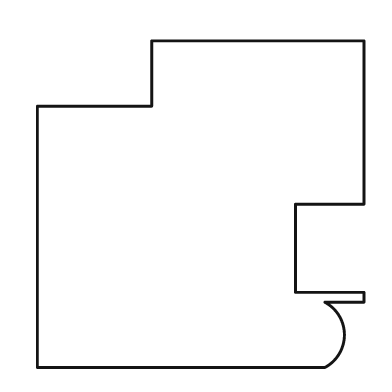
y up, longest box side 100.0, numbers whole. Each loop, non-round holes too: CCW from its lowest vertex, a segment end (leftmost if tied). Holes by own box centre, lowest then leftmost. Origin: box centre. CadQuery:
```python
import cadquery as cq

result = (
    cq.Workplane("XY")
    .moveTo(-50.0, -50.0)
    .lineTo(38.0, -50.0)
    .threePointArc((44.0, -40.0), (38.0, -30.0))
    .lineTo(50.0, -30.0)
    .lineTo(50.0, -27.0)
    .lineTo(29.0, -27.0)
    .lineTo(29.0, 0.0)
    .lineTo(50.0, 0.0)
    .lineTo(50.0, 50.0)
    .lineTo(-15.0, 50.0)
    .lineTo(-15.0, 30.0)
    .lineTo(-50.0, 30.0)
    .close()
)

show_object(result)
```